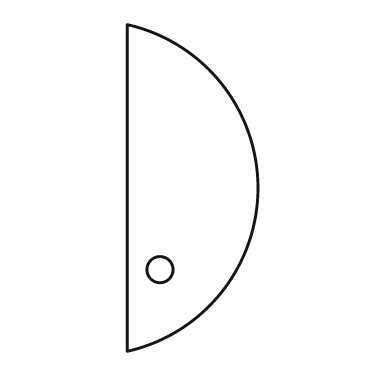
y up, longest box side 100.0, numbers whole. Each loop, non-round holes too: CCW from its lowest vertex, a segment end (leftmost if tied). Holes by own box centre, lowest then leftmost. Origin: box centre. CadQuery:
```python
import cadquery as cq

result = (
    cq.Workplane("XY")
    .moveTo(-20.0, -50.0)
    .threePointArc((20.0, 0.0), (-20.0, 50.0))
    .close()
    .moveTo(-10.0, -25.0)
    .circle(4.0)
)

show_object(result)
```